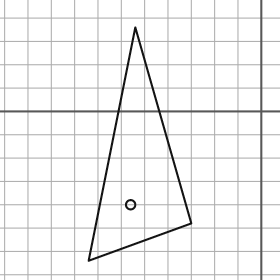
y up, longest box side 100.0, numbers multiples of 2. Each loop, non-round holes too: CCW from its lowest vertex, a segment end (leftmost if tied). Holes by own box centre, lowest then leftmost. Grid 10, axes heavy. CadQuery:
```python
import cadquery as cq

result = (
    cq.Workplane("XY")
    .moveTo(-74.0, -64.0)
    .lineTo(-30.0, -48.0)
    .lineTo(-54.0, 36.0)
    .close()
    .moveTo(-56.0, -40.0)
    .circle(2.0)
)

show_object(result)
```